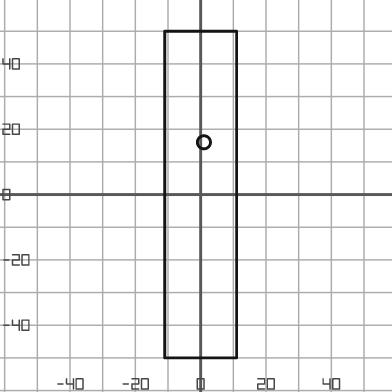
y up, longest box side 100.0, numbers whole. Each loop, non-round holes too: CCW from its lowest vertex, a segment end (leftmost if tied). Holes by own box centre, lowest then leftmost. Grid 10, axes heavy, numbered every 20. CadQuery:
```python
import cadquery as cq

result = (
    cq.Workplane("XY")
    .moveTo(-11.0, -50.0)
    .lineTo(11.0, -50.0)
    .lineTo(11.0, 50.0)
    .lineTo(-11.0, 50.0)
    .close()
    .moveTo(1.0, 16.0)
    .circle(2.0)
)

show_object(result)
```